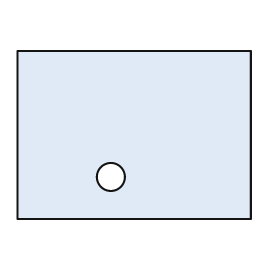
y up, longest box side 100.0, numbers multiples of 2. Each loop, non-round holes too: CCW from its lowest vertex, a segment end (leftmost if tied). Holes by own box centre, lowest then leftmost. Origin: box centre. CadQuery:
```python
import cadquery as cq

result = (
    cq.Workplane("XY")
    .moveTo(-50.0, -36.0)
    .lineTo(50.0, -36.0)
    .lineTo(50.0, 36.0)
    .lineTo(-50.0, 36.0)
    .close()
    .moveTo(-10.0, -18.0)
    .circle(6.0)
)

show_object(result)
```